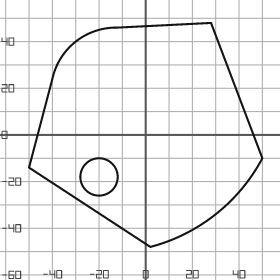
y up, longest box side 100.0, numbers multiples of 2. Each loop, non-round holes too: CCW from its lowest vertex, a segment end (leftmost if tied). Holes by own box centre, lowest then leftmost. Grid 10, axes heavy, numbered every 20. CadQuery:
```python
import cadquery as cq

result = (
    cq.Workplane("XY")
    .moveTo(2.0, -48.0)
    .threePointArc((30.0, -34.0), (50.0, -10.0))
    .lineTo(28.0, 48.0)
    .lineTo(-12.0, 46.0)
    .threePointArc((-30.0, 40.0), (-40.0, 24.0))
    .lineTo(-50.0, -14.0)
    .close()
    .moveTo(-20.0, -18.0)
    .circle(8.0)
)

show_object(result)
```